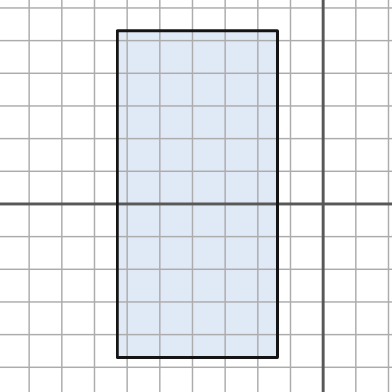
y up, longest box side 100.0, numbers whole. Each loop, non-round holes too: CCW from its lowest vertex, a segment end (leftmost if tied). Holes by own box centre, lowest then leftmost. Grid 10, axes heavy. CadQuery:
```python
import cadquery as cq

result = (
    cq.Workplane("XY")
    .moveTo(-63.0, -47.0)
    .lineTo(-14.0, -47.0)
    .lineTo(-14.0, 53.0)
    .lineTo(-63.0, 53.0)
    .close()
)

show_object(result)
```